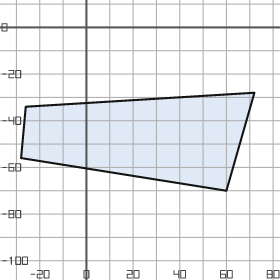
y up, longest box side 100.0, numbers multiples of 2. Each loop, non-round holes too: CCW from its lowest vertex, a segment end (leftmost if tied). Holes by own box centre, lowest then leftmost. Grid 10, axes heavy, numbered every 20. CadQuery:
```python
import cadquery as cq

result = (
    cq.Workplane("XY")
    .moveTo(60.0, -70.0)
    .lineTo(72.0, -28.0)
    .lineTo(-26.0, -34.0)
    .lineTo(-28.0, -56.0)
    .close()
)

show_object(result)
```